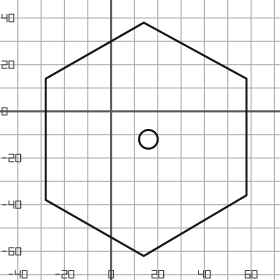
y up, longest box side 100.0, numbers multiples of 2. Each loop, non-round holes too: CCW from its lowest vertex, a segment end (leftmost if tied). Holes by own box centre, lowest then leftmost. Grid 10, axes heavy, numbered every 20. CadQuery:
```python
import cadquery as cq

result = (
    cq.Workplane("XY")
    .moveTo(14.0, -62.0)
    .lineTo(58.0, -36.0)
    .lineTo(58.0, 14.0)
    .lineTo(14.0, 38.0)
    .lineTo(-28.0, 14.0)
    .lineTo(-28.0, -38.0)
    .close()
    .moveTo(16.0, -12.0)
    .circle(4.0)
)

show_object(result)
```